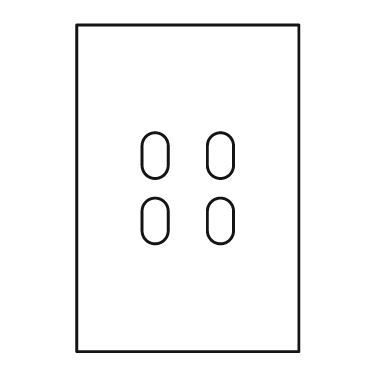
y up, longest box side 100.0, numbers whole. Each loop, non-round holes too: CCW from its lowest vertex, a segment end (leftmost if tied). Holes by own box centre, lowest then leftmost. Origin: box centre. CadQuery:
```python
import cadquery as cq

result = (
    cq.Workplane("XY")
    .moveTo(-34.0, -50.0)
    .lineTo(34.0, -50.0)
    .lineTo(34.0, 50.0)
    .lineTo(-34.0, 50.0)
    .close()
    .moveTo(-14.0, -13.0)
    .threePointArc((-10.0, -17.0), (-6.0, -13.0))
    .lineTo(-6.0, -7.0)
    .threePointArc((-10.0, -3.0), (-14.0, -7.0))
    .close()
    .moveTo(6.0, -13.0)
    .threePointArc((10.0, -17.0), (14.0, -13.0))
    .lineTo(14.0, -7.0)
    .threePointArc((10.0, -3.0), (6.0, -7.0))
    .close()
    .moveTo(-14.0, 7.0)
    .threePointArc((-10.0, 3.0), (-6.0, 7.0))
    .lineTo(-6.0, 13.0)
    .threePointArc((-10.0, 17.0), (-14.0, 13.0))
    .close()
    .moveTo(6.0, 7.0)
    .threePointArc((10.0, 3.0), (14.0, 7.0))
    .lineTo(14.0, 13.0)
    .threePointArc((10.0, 17.0), (6.0, 13.0))
    .close()
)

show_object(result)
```